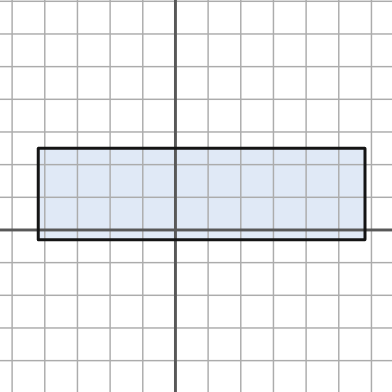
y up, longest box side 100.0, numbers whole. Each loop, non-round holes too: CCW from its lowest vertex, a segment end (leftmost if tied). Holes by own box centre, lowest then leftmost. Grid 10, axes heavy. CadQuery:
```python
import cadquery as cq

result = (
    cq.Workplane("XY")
    .moveTo(-42.0, -3.0)
    .lineTo(58.0, -3.0)
    .lineTo(58.0, 25.0)
    .lineTo(-42.0, 25.0)
    .close()
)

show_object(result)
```